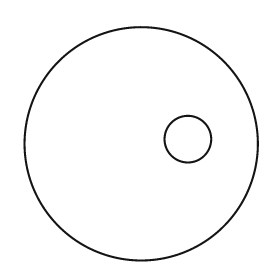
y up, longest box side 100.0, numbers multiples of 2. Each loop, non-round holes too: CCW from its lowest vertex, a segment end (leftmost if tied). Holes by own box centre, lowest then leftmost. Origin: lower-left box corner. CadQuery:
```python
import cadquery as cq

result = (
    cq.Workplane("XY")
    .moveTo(50.0, 50.0)
    .circle(50.0)
    .moveTo(70.0, 52.0)
    .circle(10.0)
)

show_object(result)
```